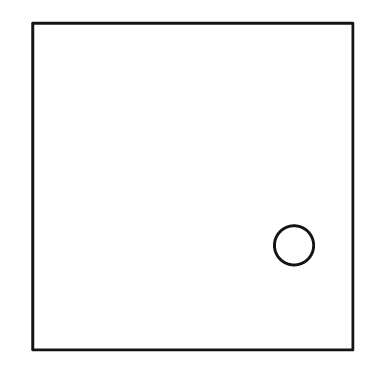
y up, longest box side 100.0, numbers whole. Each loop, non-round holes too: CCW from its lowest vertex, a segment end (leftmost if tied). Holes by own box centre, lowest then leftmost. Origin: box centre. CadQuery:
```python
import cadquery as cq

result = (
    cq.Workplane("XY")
    .moveTo(-49.0, -50.0)
    .lineTo(49.0, -50.0)
    .lineTo(49.0, 50.0)
    .lineTo(-49.0, 50.0)
    .close()
    .moveTo(31.0, -18.0)
    .circle(6.0)
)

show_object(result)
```